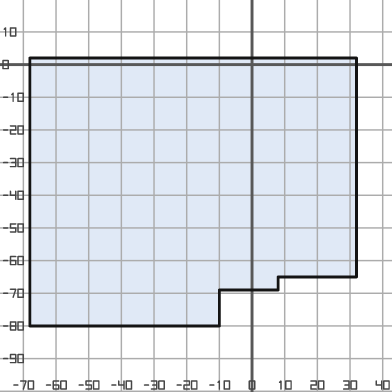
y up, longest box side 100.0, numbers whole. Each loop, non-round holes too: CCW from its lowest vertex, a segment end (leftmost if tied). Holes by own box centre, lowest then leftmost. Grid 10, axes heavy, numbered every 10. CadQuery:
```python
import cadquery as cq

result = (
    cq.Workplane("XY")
    .moveTo(-68.0, -80.0)
    .lineTo(-10.0, -80.0)
    .lineTo(-10.0, -69.0)
    .lineTo(8.0, -69.0)
    .lineTo(8.0, -65.0)
    .lineTo(32.0, -65.0)
    .lineTo(32.0, 2.0)
    .lineTo(-68.0, 2.0)
    .close()
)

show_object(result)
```